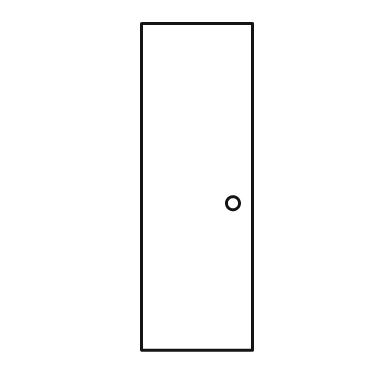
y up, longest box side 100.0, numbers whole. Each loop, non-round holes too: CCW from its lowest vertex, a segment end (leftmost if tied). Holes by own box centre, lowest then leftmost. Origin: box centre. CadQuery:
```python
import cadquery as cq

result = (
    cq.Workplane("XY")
    .moveTo(-17.0, -50.0)
    .lineTo(17.0, -50.0)
    .lineTo(17.0, 50.0)
    .lineTo(-17.0, 50.0)
    .close()
    .moveTo(11.0, -5.0)
    .circle(2.0)
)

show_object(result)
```